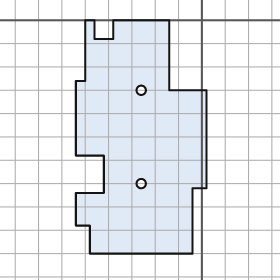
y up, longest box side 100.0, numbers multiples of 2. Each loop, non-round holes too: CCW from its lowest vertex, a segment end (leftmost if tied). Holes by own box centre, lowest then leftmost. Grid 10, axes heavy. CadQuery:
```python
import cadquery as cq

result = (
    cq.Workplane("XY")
    .moveTo(-48.0, -100.0)
    .lineTo(-4.0, -100.0)
    .lineTo(-4.0, -72.0)
    .lineTo(2.0, -72.0)
    .lineTo(2.0, -30.0)
    .lineTo(-14.0, -30.0)
    .lineTo(-14.0, 0.0)
    .lineTo(-38.0, 0.0)
    .lineTo(-38.0, -8.0)
    .lineTo(-46.0, -8.0)
    .lineTo(-46.0, 0.0)
    .lineTo(-50.0, 0.0)
    .lineTo(-50.0, -26.0)
    .lineTo(-54.0, -26.0)
    .lineTo(-54.0, -58.0)
    .lineTo(-42.0, -58.0)
    .lineTo(-42.0, -74.0)
    .lineTo(-54.0, -74.0)
    .lineTo(-54.0, -88.0)
    .lineTo(-48.0, -88.0)
    .close()
    .moveTo(-26.0, -70.0)
    .circle(2.0)
    .moveTo(-26.0, -30.0)
    .circle(2.0)
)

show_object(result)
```